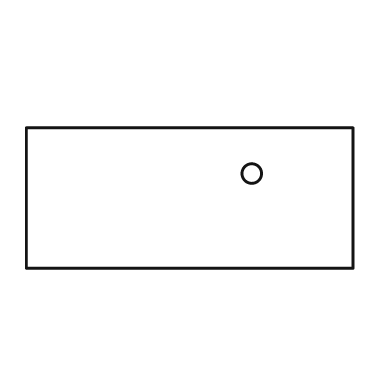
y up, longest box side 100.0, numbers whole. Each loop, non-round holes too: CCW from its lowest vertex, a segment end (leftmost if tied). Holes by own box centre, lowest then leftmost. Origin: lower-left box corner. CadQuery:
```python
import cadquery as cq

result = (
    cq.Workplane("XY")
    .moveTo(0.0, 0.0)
    .lineTo(100.0, 0.0)
    .lineTo(100.0, 43.0)
    .lineTo(0.0, 43.0)
    .close()
    .moveTo(69.0, 29.0)
    .circle(3.0)
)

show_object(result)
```